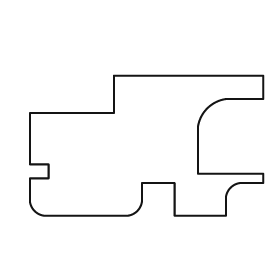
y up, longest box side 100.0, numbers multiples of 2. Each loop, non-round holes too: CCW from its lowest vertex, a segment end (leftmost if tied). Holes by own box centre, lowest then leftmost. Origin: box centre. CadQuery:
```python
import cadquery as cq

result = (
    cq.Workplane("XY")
    .moveTo(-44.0, -30.0)
    .lineTo(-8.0, -30.0)
    .threePointArc((-4.0, -28.0), (-2.0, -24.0))
    .lineTo(-2.0, -16.0)
    .lineTo(12.0, -16.0)
    .lineTo(12.0, -30.0)
    .lineTo(34.0, -30.0)
    .lineTo(34.0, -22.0)
    .threePointArc((36.0, -18.0), (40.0, -16.0))
    .lineTo(50.0, -16.0)
    .lineTo(50.0, -12.0)
    .lineTo(22.0, -12.0)
    .lineTo(22.0, 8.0)
    .threePointArc((26.0, 16.0), (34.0, 20.0))
    .lineTo(50.0, 20.0)
    .lineTo(50.0, 30.0)
    .lineTo(-14.0, 30.0)
    .lineTo(-14.0, 14.0)
    .lineTo(-50.0, 14.0)
    .lineTo(-50.0, -8.0)
    .lineTo(-42.0, -8.0)
    .lineTo(-42.0, -14.0)
    .lineTo(-50.0, -14.0)
    .lineTo(-50.0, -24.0)
    .threePointArc((-48.0, -28.0), (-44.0, -30.0))
    .close()
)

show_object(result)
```